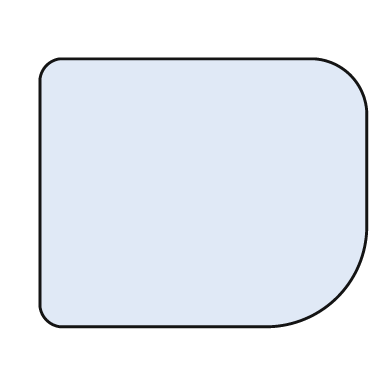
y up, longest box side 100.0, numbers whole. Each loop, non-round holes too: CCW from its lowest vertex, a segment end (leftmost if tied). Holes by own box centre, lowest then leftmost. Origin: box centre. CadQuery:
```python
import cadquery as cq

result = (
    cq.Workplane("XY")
    .moveTo(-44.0, -41.0)
    .lineTo(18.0, -41.0)
    .threePointArc((41.0, -32.0), (50.0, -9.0))
    .lineTo(50.0, 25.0)
    .threePointArc((45.0, 36.0), (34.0, 41.0))
    .lineTo(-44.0, 41.0)
    .threePointArc((-48.0, 39.0), (-50.0, 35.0))
    .lineTo(-50.0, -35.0)
    .threePointArc((-48.0, -39.0), (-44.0, -41.0))
    .close()
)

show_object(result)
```